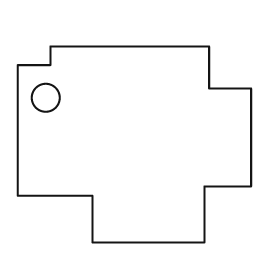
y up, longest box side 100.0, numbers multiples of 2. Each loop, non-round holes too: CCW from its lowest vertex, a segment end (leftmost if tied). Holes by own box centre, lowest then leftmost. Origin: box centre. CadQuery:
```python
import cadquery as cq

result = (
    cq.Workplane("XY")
    .moveTo(-18.0, -42.0)
    .lineTo(30.0, -42.0)
    .lineTo(30.0, -18.0)
    .lineTo(50.0, -18.0)
    .lineTo(50.0, 24.0)
    .lineTo(32.0, 24.0)
    .lineTo(32.0, 42.0)
    .lineTo(-36.0, 42.0)
    .lineTo(-36.0, 34.0)
    .lineTo(-50.0, 34.0)
    .lineTo(-50.0, -22.0)
    .lineTo(-18.0, -22.0)
    .close()
    .moveTo(-38.0, 20.0)
    .circle(6.0)
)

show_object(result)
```